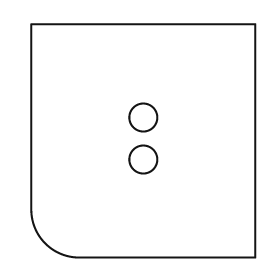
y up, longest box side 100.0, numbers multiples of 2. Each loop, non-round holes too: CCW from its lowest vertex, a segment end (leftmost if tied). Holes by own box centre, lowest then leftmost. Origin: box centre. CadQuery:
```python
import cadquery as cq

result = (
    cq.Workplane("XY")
    .moveTo(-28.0, -50.0)
    .lineTo(48.0, -50.0)
    .lineTo(48.0, 50.0)
    .lineTo(-48.0, 50.0)
    .lineTo(-48.0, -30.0)
    .threePointArc((-42.0, -44.0), (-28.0, -50.0))
    .close()
    .moveTo(0.0, -8.0)
    .circle(6.0)
    .moveTo(0.0, 10.0)
    .circle(6.0)
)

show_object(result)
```